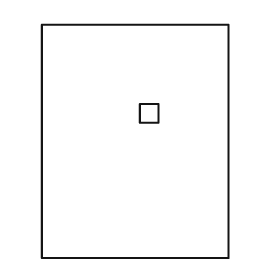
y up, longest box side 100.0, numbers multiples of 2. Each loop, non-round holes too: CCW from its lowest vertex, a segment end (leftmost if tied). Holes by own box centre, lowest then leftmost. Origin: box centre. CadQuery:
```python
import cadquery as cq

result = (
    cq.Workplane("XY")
    .moveTo(-40.0, -50.0)
    .lineTo(40.0, -50.0)
    .lineTo(40.0, 50.0)
    .lineTo(-40.0, 50.0)
    .close()
    .moveTo(2.0, 8.0)
    .lineTo(10.0, 8.0)
    .lineTo(10.0, 16.0)
    .lineTo(2.0, 16.0)
    .close()
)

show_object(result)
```